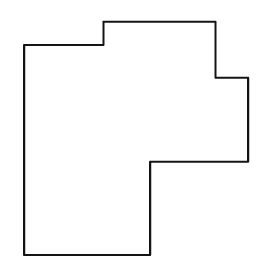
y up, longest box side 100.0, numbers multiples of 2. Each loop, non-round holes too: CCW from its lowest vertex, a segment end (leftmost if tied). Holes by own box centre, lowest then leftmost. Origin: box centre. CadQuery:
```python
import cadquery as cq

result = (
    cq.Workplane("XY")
    .moveTo(-48.0, -50.0)
    .lineTo(6.0, -50.0)
    .lineTo(6.0, -10.0)
    .lineTo(48.0, -10.0)
    .lineTo(48.0, 26.0)
    .lineTo(34.0, 26.0)
    .lineTo(34.0, 50.0)
    .lineTo(-14.0, 50.0)
    .lineTo(-14.0, 40.0)
    .lineTo(-48.0, 40.0)
    .close()
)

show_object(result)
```